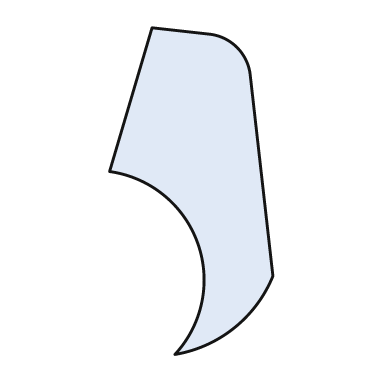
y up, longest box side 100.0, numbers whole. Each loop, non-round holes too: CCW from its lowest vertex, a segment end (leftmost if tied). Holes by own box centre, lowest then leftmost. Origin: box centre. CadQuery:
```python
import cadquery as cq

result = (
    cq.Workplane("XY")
    .moveTo(-5.0, -50.0)
    .threePointArc((13.0, -42.0), (25.0, -26.0))
    .lineTo(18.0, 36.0)
    .threePointArc((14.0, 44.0), (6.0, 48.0))
    .lineTo(-12.0, 50.0)
    .lineTo(-25.0, 6.0)
    .threePointArc((2.0, -16.0), (-5.0, -50.0))
    .close()
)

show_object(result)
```